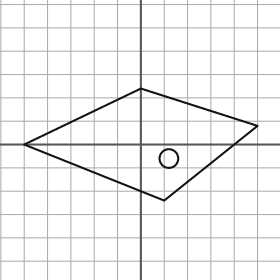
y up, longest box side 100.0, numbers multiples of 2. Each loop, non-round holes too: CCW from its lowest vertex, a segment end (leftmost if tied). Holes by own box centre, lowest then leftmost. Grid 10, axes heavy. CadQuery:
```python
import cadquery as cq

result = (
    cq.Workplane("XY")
    .moveTo(10.0, -24.0)
    .lineTo(50.0, 8.0)
    .lineTo(0.0, 24.0)
    .lineTo(-50.0, 0.0)
    .close()
    .moveTo(12.0, -6.0)
    .circle(4.0)
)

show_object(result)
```